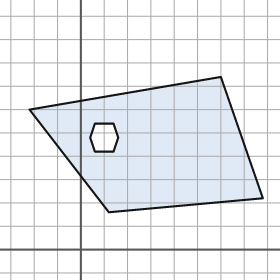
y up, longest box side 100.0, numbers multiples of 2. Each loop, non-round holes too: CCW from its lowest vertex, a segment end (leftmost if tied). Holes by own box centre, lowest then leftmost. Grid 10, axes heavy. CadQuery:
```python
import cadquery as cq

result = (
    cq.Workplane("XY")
    .moveTo(12.0, 16.0)
    .lineTo(78.0, 22.0)
    .lineTo(60.0, 74.0)
    .lineTo(-22.0, 60.0)
    .close()
    .moveTo(6.0, 42.0)
    .lineTo(14.0, 42.0)
    .lineTo(16.0, 48.0)
    .lineTo(14.0, 54.0)
    .lineTo(6.0, 54.0)
    .lineTo(4.0, 48.0)
    .close()
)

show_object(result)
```